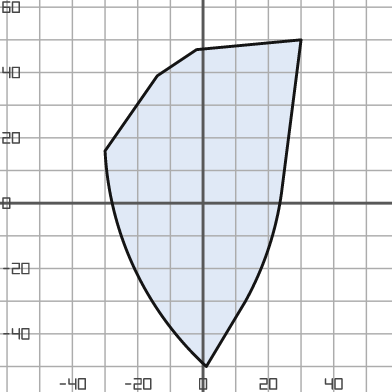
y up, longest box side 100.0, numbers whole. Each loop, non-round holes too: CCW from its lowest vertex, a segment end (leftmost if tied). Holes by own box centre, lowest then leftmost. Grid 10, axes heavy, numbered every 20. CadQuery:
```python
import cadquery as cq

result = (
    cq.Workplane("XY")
    .moveTo(1.0, -50.0)
    .lineTo(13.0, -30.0)
    .threePointArc((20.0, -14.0), (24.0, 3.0))
    .lineTo(30.0, 50.0)
    .lineTo(-2.0, 47.0)
    .lineTo(-14.0, 39.0)
    .lineTo(-30.0, 16.0)
    .threePointArc((-21.0, -20.0), (1.0, -50.0))
    .close()
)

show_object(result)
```